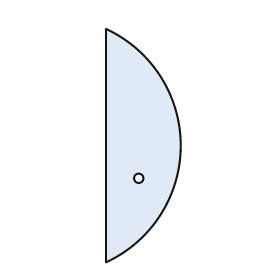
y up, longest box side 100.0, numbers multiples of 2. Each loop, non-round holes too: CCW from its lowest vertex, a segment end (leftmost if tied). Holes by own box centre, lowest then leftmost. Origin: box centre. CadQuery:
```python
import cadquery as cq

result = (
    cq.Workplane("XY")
    .moveTo(-16.0, -50.0)
    .threePointArc((16.0, 0.0), (-16.0, 50.0))
    .close()
    .moveTo(-2.0, -14.0)
    .circle(2.0)
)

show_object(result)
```